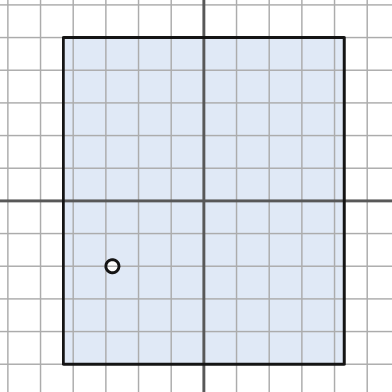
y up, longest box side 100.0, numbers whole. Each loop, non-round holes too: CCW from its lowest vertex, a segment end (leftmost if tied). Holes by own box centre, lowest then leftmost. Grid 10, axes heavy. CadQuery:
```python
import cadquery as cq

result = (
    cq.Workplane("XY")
    .moveTo(-43.0, -50.0)
    .lineTo(43.0, -50.0)
    .lineTo(43.0, 50.0)
    .lineTo(-43.0, 50.0)
    .close()
    .moveTo(-28.0, -20.0)
    .circle(2.0)
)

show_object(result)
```